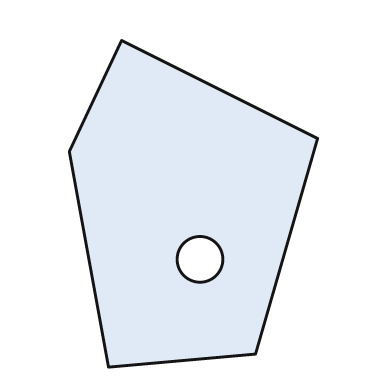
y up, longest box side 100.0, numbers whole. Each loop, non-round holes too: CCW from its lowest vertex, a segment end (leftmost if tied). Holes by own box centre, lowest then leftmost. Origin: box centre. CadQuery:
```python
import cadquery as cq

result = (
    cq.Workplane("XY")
    .moveTo(-26.0, -50.0)
    .lineTo(19.0, -46.0)
    .lineTo(38.0, 20.0)
    .lineTo(-22.0, 50.0)
    .lineTo(-38.0, 16.0)
    .close()
    .moveTo(2.0, -17.0)
    .circle(7.0)
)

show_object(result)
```